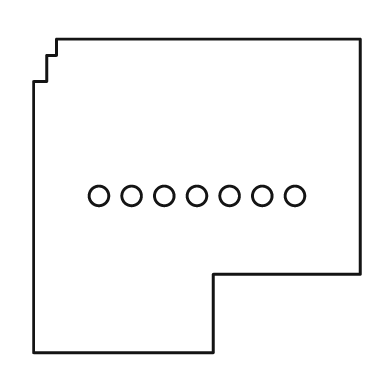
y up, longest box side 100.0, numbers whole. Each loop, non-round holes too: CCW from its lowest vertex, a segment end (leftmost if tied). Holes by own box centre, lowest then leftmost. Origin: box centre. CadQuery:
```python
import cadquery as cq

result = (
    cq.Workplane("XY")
    .moveTo(-50.0, -48.0)
    .lineTo(5.0, -48.0)
    .lineTo(5.0, -24.0)
    .lineTo(50.0, -24.0)
    .lineTo(50.0, 48.0)
    .lineTo(-43.0, 48.0)
    .lineTo(-43.0, 43.0)
    .lineTo(-46.0, 43.0)
    .lineTo(-46.0, 35.0)
    .lineTo(-50.0, 35.0)
    .close()
    .moveTo(-30.0, 0.0)
    .circle(3.0)
    .moveTo(-20.0, 0.0)
    .circle(3.0)
    .moveTo(-10.0, 0.0)
    .circle(3.0)
    .moveTo(0.0, 0.0)
    .circle(3.0)
    .moveTo(10.0, 0.0)
    .circle(3.0)
    .moveTo(20.0, 0.0)
    .circle(3.0)
    .moveTo(30.0, 0.0)
    .circle(3.0)
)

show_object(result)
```